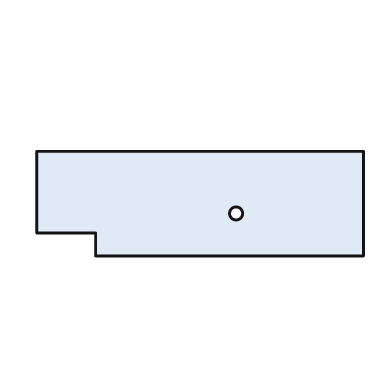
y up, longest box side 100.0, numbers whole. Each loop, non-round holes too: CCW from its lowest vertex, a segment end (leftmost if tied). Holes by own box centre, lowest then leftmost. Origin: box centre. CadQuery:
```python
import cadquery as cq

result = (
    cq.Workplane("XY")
    .moveTo(-32.0, -16.0)
    .lineTo(50.0, -16.0)
    .lineTo(50.0, 16.0)
    .lineTo(-50.0, 16.0)
    .lineTo(-50.0, -9.0)
    .lineTo(-32.0, -9.0)
    .close()
    .moveTo(11.0, -3.0)
    .circle(2.0)
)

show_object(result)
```